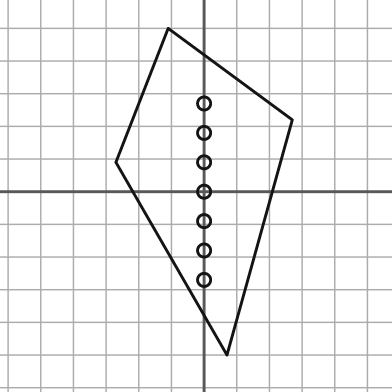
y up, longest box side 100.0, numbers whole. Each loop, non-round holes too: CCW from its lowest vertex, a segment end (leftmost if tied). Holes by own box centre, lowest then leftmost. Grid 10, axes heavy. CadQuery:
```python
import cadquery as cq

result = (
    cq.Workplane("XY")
    .moveTo(7.0, -50.0)
    .lineTo(27.0, 22.0)
    .lineTo(-11.0, 50.0)
    .lineTo(-27.0, 9.0)
    .close()
    .moveTo(0.0, -27.0)
    .circle(2.0)
    .moveTo(0.0, -18.0)
    .circle(2.0)
    .moveTo(0.0, -9.0)
    .circle(2.0)
    .moveTo(0.0, 0.0)
    .circle(2.0)
    .moveTo(0.0, 9.0)
    .circle(2.0)
    .moveTo(0.0, 18.0)
    .circle(2.0)
    .moveTo(0.0, 27.0)
    .circle(2.0)
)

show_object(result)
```